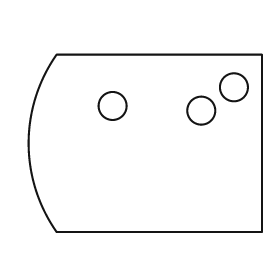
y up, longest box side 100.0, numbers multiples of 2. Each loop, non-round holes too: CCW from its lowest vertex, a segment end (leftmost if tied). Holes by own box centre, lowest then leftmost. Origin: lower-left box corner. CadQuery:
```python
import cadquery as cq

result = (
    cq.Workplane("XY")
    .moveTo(12.0, 0.0)
    .lineTo(100.0, 0.0)
    .lineTo(100.0, 76.0)
    .lineTo(12.0, 76.0)
    .threePointArc((0.0, 38.0), (12.0, 0.0))
    .close()
    .moveTo(74.0, 52.0)
    .circle(6.0)
    .moveTo(36.0, 54.0)
    .circle(6.0)
    .moveTo(88.0, 62.0)
    .circle(6.0)
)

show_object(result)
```